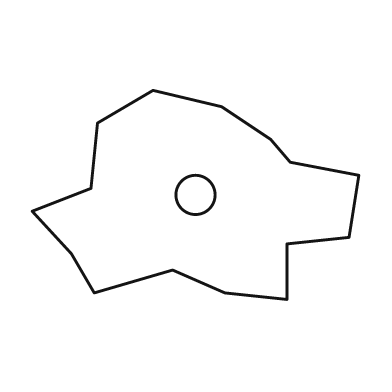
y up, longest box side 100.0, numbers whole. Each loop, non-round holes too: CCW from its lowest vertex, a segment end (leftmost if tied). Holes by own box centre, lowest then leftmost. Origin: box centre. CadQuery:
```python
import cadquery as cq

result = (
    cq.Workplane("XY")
    .moveTo(28.0, -32.0)
    .lineTo(28.0, -15.0)
    .lineTo(47.0, -13.0)
    .lineTo(50.0, 6.0)
    .lineTo(29.0, 10.0)
    .lineTo(23.0, 17.0)
    .lineTo(8.0, 27.0)
    .lineTo(-13.0, 32.0)
    .lineTo(-30.0, 22.0)
    .lineTo(-32.0, 2.0)
    .lineTo(-50.0, -5.0)
    .lineTo(-38.0, -18.0)
    .lineTo(-31.0, -30.0)
    .lineTo(-7.0, -23.0)
    .lineTo(9.0, -30.0)
    .close()
    .moveTo(0.0, 0.0)
    .circle(6.0)
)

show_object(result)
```